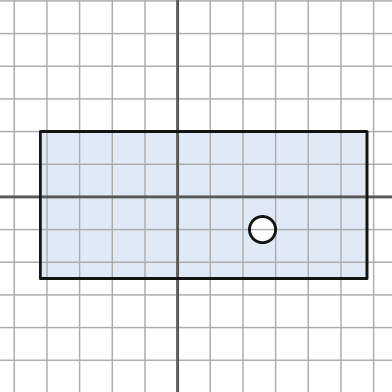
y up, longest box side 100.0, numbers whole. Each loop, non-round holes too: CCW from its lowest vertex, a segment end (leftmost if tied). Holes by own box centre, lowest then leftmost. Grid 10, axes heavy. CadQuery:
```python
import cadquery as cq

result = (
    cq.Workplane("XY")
    .moveTo(-42.0, -25.0)
    .lineTo(58.0, -25.0)
    .lineTo(58.0, 20.0)
    .lineTo(-42.0, 20.0)
    .close()
    .moveTo(26.0, -10.0)
    .circle(4.0)
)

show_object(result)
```